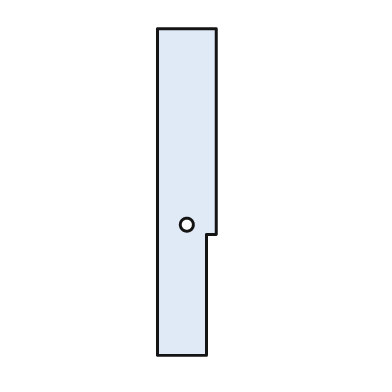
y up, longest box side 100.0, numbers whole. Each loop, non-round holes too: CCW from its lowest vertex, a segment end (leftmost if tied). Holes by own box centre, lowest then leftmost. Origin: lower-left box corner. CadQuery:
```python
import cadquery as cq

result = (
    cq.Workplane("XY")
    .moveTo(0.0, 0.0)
    .lineTo(15.0, 0.0)
    .lineTo(15.0, 37.0)
    .lineTo(18.0, 37.0)
    .lineTo(18.0, 100.0)
    .lineTo(0.0, 100.0)
    .close()
    .moveTo(9.0, 40.0)
    .circle(2.0)
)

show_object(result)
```